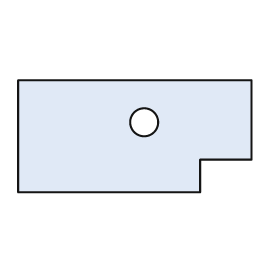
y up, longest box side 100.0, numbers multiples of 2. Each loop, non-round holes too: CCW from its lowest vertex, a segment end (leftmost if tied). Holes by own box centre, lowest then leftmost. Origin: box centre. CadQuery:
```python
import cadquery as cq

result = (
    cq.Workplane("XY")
    .moveTo(-50.0, -24.0)
    .lineTo(28.0, -24.0)
    .lineTo(28.0, -10.0)
    .lineTo(50.0, -10.0)
    .lineTo(50.0, 24.0)
    .lineTo(-50.0, 24.0)
    .close()
    .moveTo(4.0, 6.0)
    .circle(6.0)
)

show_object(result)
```